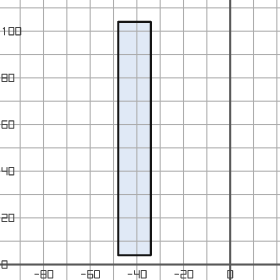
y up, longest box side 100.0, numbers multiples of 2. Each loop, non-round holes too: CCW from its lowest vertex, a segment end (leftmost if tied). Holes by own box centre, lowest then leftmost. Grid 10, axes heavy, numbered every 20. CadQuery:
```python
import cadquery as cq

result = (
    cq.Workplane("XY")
    .moveTo(-48.0, 4.0)
    .lineTo(-34.0, 4.0)
    .lineTo(-34.0, 104.0)
    .lineTo(-48.0, 104.0)
    .close()
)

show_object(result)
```